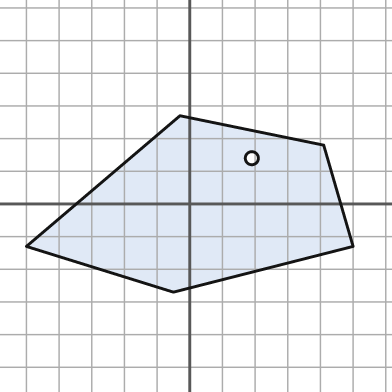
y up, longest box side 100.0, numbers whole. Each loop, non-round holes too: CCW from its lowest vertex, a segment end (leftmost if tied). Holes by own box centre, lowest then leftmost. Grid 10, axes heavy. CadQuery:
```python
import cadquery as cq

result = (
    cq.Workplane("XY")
    .moveTo(-5.0, -27.0)
    .lineTo(50.0, -13.0)
    .lineTo(41.0, 18.0)
    .lineTo(-3.0, 27.0)
    .lineTo(-50.0, -13.0)
    .close()
    .moveTo(19.0, 14.0)
    .circle(2.0)
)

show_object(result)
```